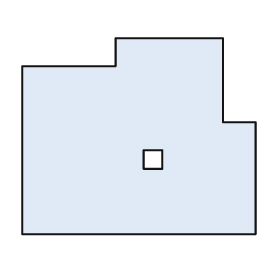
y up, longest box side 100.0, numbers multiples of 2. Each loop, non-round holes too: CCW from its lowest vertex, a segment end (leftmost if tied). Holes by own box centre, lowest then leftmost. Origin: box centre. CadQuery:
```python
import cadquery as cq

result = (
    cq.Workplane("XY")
    .moveTo(-50.0, -42.0)
    .lineTo(50.0, -42.0)
    .lineTo(50.0, 6.0)
    .lineTo(36.0, 6.0)
    .lineTo(36.0, 42.0)
    .lineTo(-10.0, 42.0)
    .lineTo(-10.0, 30.0)
    .lineTo(-50.0, 30.0)
    .close()
    .moveTo(2.0, -14.0)
    .lineTo(10.0, -14.0)
    .lineTo(10.0, -6.0)
    .lineTo(2.0, -6.0)
    .close()
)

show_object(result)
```